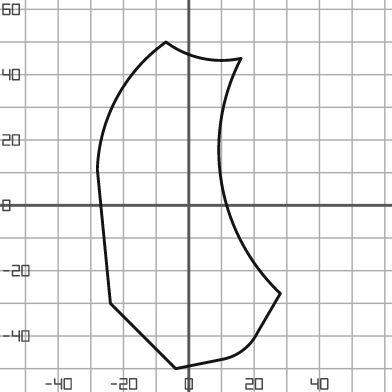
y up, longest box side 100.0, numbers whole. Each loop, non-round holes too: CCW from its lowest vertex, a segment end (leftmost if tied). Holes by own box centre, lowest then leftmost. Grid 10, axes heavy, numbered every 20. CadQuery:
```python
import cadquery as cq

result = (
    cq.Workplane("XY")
    .moveTo(-4.0, -50.0)
    .lineTo(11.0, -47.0)
    .threePointArc((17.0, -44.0), (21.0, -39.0))
    .lineTo(28.0, -27.0)
    .threePointArc((10.0, 7.0), (16.0, 45.0))
    .threePointArc((4.0, 45.0), (-7.0, 50.0))
    .threePointArc((-22.0, 33.0), (-28.0, 11.0))
    .lineTo(-24.0, -30.0)
    .close()
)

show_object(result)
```